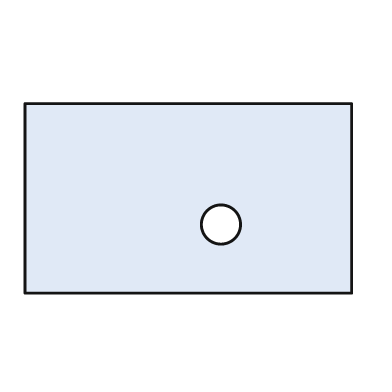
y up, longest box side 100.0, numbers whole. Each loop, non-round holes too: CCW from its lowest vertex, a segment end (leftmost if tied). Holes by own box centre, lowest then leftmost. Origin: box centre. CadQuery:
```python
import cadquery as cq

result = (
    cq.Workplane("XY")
    .moveTo(-50.0, -29.0)
    .lineTo(50.0, -29.0)
    .lineTo(50.0, 29.0)
    .lineTo(-50.0, 29.0)
    .close()
    .moveTo(10.0, -8.0)
    .circle(6.0)
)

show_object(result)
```